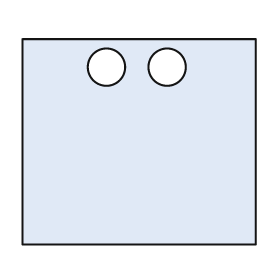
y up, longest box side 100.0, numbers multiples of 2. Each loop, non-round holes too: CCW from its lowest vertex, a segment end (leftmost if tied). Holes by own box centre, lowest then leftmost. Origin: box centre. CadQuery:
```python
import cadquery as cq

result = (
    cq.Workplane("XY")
    .moveTo(-50.0, -44.0)
    .lineTo(50.0, -44.0)
    .lineTo(50.0, 44.0)
    .lineTo(-50.0, 44.0)
    .close()
    .moveTo(-14.0, 32.0)
    .circle(8.0)
    .moveTo(12.0, 32.0)
    .circle(8.0)
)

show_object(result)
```